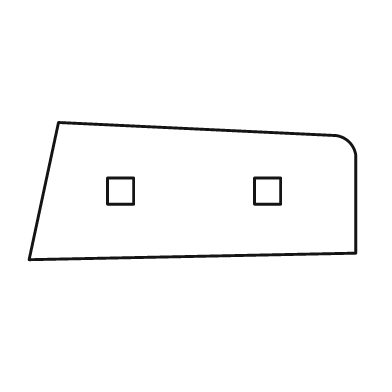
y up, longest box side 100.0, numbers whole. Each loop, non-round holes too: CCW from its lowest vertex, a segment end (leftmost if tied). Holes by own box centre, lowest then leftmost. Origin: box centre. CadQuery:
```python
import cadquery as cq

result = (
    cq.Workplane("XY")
    .moveTo(-50.0, -21.0)
    .lineTo(50.0, -19.0)
    .lineTo(50.0, 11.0)
    .threePointArc((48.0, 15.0), (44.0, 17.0))
    .lineTo(-41.0, 21.0)
    .close()
    .moveTo(-26.0, -4.0)
    .lineTo(-18.0, -4.0)
    .lineTo(-18.0, 4.0)
    .lineTo(-26.0, 4.0)
    .close()
    .moveTo(19.0, -4.0)
    .lineTo(27.0, -4.0)
    .lineTo(27.0, 4.0)
    .lineTo(19.0, 4.0)
    .close()
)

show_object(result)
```